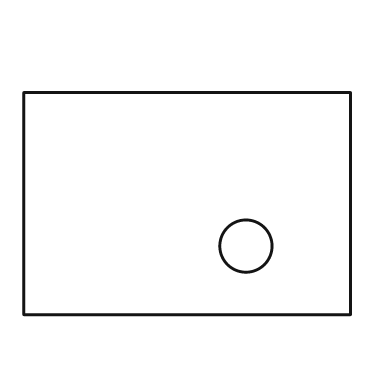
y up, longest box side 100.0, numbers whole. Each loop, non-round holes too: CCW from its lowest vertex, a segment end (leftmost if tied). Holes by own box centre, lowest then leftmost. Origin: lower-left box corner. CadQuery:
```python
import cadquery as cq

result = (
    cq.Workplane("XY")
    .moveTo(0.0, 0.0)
    .lineTo(100.0, 0.0)
    .lineTo(100.0, 68.0)
    .lineTo(0.0, 68.0)
    .close()
    .moveTo(68.0, 21.0)
    .circle(8.0)
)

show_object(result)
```